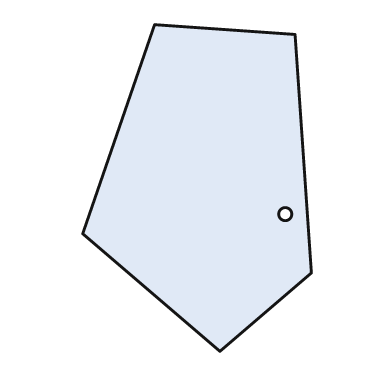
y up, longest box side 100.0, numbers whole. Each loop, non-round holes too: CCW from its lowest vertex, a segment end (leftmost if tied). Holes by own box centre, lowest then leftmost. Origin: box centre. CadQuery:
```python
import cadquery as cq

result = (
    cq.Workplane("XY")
    .moveTo(7.0, -50.0)
    .lineTo(35.0, -26.0)
    .lineTo(30.0, 47.0)
    .lineTo(-13.0, 50.0)
    .lineTo(-35.0, -14.0)
    .close()
    .moveTo(27.0, -8.0)
    .circle(2.0)
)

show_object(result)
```